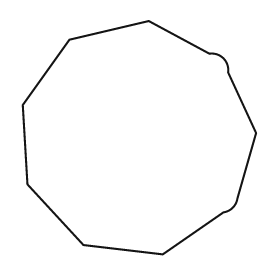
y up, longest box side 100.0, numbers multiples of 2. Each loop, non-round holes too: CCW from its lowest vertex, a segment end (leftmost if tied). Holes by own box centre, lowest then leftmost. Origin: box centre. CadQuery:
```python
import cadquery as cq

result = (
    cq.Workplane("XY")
    .moveTo(10.0, -50.0)
    .lineTo(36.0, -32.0)
    .threePointArc((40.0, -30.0), (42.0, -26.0))
    .lineTo(50.0, 2.0)
    .lineTo(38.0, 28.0)
    .threePointArc((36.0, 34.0), (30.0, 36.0))
    .lineTo(4.0, 50.0)
    .lineTo(-30.0, 42.0)
    .lineTo(-50.0, 14.0)
    .lineTo(-48.0, -20.0)
    .lineTo(-24.0, -46.0)
    .close()
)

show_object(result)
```